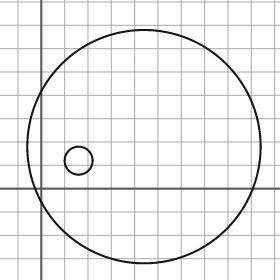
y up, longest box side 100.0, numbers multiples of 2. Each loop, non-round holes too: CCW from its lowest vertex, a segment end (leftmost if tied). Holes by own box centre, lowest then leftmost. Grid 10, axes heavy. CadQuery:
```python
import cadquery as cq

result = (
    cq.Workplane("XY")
    .moveTo(44.0, 18.0)
    .circle(50.0)
    .moveTo(16.0, 12.0)
    .circle(6.0)
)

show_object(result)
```